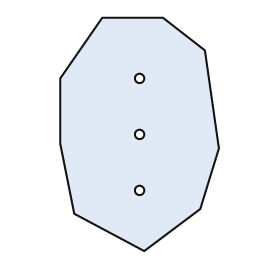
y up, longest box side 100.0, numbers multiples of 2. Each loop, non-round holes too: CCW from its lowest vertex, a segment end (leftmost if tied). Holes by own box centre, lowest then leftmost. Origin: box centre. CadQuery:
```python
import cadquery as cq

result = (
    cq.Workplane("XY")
    .moveTo(2.0, -50.0)
    .lineTo(26.0, -32.0)
    .lineTo(34.0, -6.0)
    .lineTo(28.0, 36.0)
    .lineTo(10.0, 50.0)
    .lineTo(-16.0, 50.0)
    .lineTo(-34.0, 24.0)
    .lineTo(-34.0, -4.0)
    .lineTo(-28.0, -34.0)
    .close()
    .moveTo(0.0, -24.0)
    .circle(2.0)
    .moveTo(0.0, 0.0)
    .circle(2.0)
    .moveTo(0.0, 24.0)
    .circle(2.0)
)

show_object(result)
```